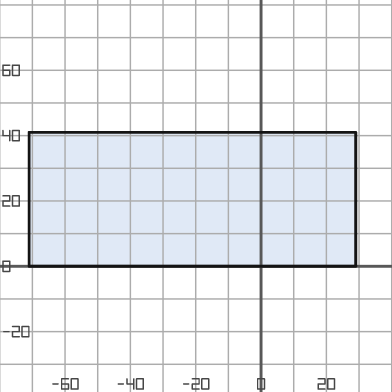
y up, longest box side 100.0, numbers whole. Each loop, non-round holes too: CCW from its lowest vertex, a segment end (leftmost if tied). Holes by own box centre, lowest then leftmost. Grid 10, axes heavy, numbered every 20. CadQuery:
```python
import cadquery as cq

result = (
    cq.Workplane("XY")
    .moveTo(-71.0, 0.0)
    .lineTo(29.0, 0.0)
    .lineTo(29.0, 41.0)
    .lineTo(-71.0, 41.0)
    .close()
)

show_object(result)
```